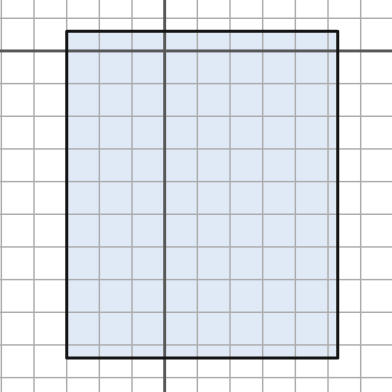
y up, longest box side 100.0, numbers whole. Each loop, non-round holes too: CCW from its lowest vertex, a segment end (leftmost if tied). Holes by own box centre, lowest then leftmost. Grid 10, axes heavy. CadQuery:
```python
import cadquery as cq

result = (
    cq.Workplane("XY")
    .moveTo(-30.0, -94.0)
    .lineTo(53.0, -94.0)
    .lineTo(53.0, 6.0)
    .lineTo(-30.0, 6.0)
    .close()
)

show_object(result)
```